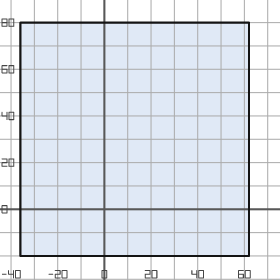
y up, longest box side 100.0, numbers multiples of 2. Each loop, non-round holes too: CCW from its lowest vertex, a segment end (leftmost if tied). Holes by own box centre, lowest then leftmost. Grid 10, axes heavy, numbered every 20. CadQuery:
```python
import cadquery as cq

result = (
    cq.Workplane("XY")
    .moveTo(-36.0, -20.0)
    .lineTo(62.0, -20.0)
    .lineTo(62.0, 80.0)
    .lineTo(-36.0, 80.0)
    .close()
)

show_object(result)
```